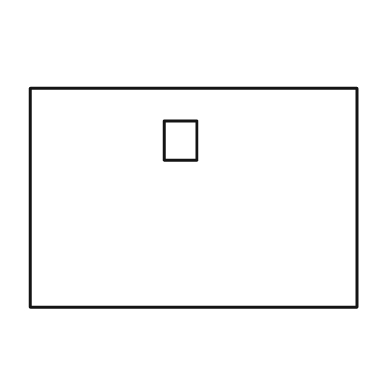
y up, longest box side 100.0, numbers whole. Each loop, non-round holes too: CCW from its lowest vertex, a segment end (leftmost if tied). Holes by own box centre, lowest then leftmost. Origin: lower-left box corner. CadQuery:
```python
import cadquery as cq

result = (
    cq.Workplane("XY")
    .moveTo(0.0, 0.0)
    .lineTo(100.0, 0.0)
    .lineTo(100.0, 67.0)
    .lineTo(0.0, 67.0)
    .close()
    .moveTo(41.0, 45.0)
    .lineTo(51.0, 45.0)
    .lineTo(51.0, 57.0)
    .lineTo(41.0, 57.0)
    .close()
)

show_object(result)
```